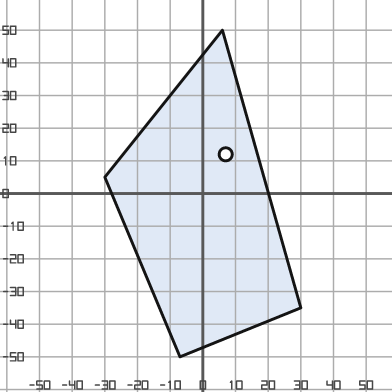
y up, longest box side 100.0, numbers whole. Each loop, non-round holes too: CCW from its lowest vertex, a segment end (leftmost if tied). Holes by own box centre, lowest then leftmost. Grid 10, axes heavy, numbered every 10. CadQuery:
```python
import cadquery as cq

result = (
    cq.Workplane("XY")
    .moveTo(-7.0, -50.0)
    .lineTo(30.0, -35.0)
    .lineTo(6.0, 50.0)
    .lineTo(-30.0, 5.0)
    .close()
    .moveTo(7.0, 12.0)
    .circle(2.0)
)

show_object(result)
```